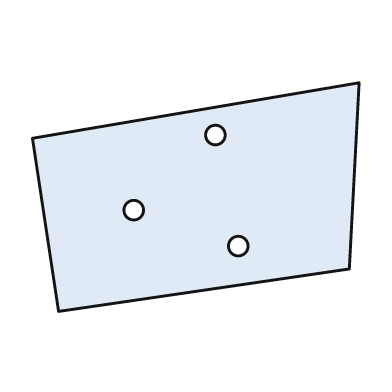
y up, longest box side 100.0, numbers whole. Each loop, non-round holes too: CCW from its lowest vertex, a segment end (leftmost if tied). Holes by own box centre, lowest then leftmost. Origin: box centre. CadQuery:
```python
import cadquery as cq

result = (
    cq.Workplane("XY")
    .moveTo(-42.0, -35.0)
    .lineTo(47.0, -22.0)
    .lineTo(50.0, 35.0)
    .lineTo(-50.0, 18.0)
    .close()
    .moveTo(13.0, -15.0)
    .circle(3.0)
    .moveTo(-19.0, -4.0)
    .circle(3.0)
    .moveTo(6.0, 19.0)
    .circle(3.0)
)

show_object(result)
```